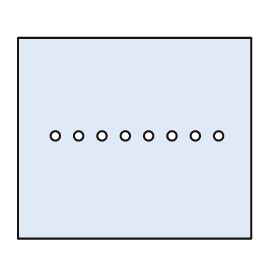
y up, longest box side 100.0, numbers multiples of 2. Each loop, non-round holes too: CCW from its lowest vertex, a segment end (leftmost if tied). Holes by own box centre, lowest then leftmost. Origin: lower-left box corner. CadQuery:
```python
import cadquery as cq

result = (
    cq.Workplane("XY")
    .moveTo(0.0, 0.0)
    .lineTo(100.0, 0.0)
    .lineTo(100.0, 86.0)
    .lineTo(0.0, 86.0)
    .close()
    .moveTo(16.0, 44.0)
    .circle(2.0)
    .moveTo(26.0, 44.0)
    .circle(2.0)
    .moveTo(36.0, 44.0)
    .circle(2.0)
    .moveTo(46.0, 44.0)
    .circle(2.0)
    .moveTo(56.0, 44.0)
    .circle(2.0)
    .moveTo(66.0, 44.0)
    .circle(2.0)
    .moveTo(76.0, 44.0)
    .circle(2.0)
    .moveTo(86.0, 44.0)
    .circle(2.0)
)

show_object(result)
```